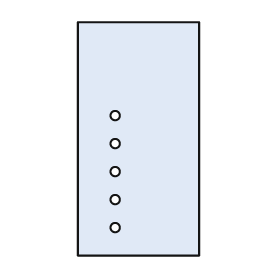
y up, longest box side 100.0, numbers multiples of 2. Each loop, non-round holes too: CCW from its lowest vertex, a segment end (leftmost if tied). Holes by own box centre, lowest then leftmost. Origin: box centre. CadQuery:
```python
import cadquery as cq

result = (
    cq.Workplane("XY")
    .moveTo(-26.0, -50.0)
    .lineTo(26.0, -50.0)
    .lineTo(26.0, 50.0)
    .lineTo(-26.0, 50.0)
    .close()
    .moveTo(-10.0, -38.0)
    .circle(2.0)
    .moveTo(-10.0, -26.0)
    .circle(2.0)
    .moveTo(-10.0, -14.0)
    .circle(2.0)
    .moveTo(-10.0, -2.0)
    .circle(2.0)
    .moveTo(-10.0, 10.0)
    .circle(2.0)
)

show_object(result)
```